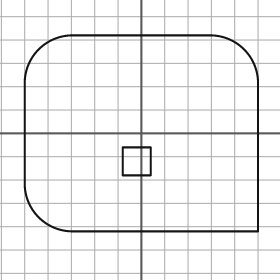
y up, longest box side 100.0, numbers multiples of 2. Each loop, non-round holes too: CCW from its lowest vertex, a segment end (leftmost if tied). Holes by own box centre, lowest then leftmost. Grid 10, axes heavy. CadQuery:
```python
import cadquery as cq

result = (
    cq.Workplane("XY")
    .moveTo(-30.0, -42.0)
    .lineTo(50.0, -42.0)
    .lineTo(50.0, 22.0)
    .threePointArc((44.0, 36.0), (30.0, 42.0))
    .lineTo(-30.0, 42.0)
    .threePointArc((-44.0, 36.0), (-50.0, 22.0))
    .lineTo(-50.0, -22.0)
    .threePointArc((-44.0, -36.0), (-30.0, -42.0))
    .close()
    .moveTo(-8.0, -18.0)
    .lineTo(4.0, -18.0)
    .lineTo(4.0, -6.0)
    .lineTo(-8.0, -6.0)
    .close()
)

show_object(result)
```